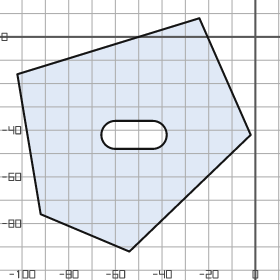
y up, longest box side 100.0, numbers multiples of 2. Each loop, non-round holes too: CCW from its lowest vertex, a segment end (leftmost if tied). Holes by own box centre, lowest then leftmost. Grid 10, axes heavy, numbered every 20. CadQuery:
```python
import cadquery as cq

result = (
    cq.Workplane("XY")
    .moveTo(-54.0, -92.0)
    .lineTo(-2.0, -42.0)
    .lineTo(-24.0, 8.0)
    .lineTo(-102.0, -16.0)
    .lineTo(-92.0, -76.0)
    .close()
    .moveTo(-60.0, -48.0)
    .lineTo(-44.0, -48.0)
    .threePointArc((-38.0, -42.0), (-44.0, -36.0))
    .lineTo(-60.0, -36.0)
    .threePointArc((-66.0, -42.0), (-60.0, -48.0))
    .close()
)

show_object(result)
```